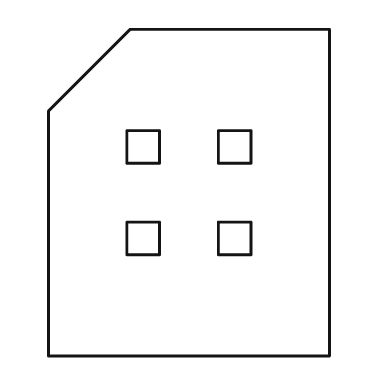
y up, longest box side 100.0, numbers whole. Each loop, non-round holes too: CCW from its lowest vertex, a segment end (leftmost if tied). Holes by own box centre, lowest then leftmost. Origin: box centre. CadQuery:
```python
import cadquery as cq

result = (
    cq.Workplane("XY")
    .moveTo(-43.0, -50.0)
    .lineTo(43.0, -50.0)
    .lineTo(43.0, 50.0)
    .lineTo(-18.0, 50.0)
    .lineTo(-43.0, 25.0)
    .close()
    .moveTo(-19.0, -19.0)
    .lineTo(-9.0, -19.0)
    .lineTo(-9.0, -9.0)
    .lineTo(-19.0, -9.0)
    .close()
    .moveTo(9.0, -19.0)
    .lineTo(19.0, -19.0)
    .lineTo(19.0, -9.0)
    .lineTo(9.0, -9.0)
    .close()
    .moveTo(-19.0, 9.0)
    .lineTo(-9.0, 9.0)
    .lineTo(-9.0, 19.0)
    .lineTo(-19.0, 19.0)
    .close()
    .moveTo(9.0, 9.0)
    .lineTo(19.0, 9.0)
    .lineTo(19.0, 19.0)
    .lineTo(9.0, 19.0)
    .close()
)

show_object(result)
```